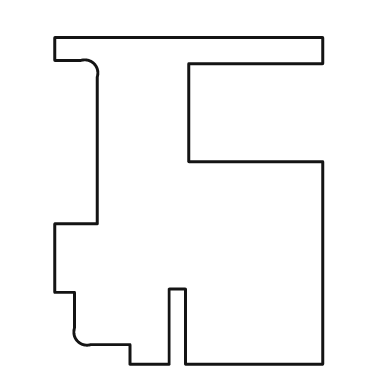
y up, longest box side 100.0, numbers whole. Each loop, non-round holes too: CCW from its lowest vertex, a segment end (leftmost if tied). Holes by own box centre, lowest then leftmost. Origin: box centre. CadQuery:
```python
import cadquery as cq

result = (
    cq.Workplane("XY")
    .moveTo(-18.0, -50.0)
    .lineTo(-6.0, -50.0)
    .lineTo(-6.0, -27.0)
    .lineTo(-1.0, -27.0)
    .lineTo(-1.0, -50.0)
    .lineTo(41.0, -50.0)
    .lineTo(41.0, 12.0)
    .lineTo(0.0, 12.0)
    .lineTo(0.0, 42.0)
    .lineTo(41.0, 42.0)
    .lineTo(41.0, 50.0)
    .lineTo(-41.0, 50.0)
    .lineTo(-41.0, 43.0)
    .lineTo(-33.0, 43.0)
    .threePointArc((-29.0, 42.0), (-28.0, 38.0))
    .lineTo(-28.0, -7.0)
    .lineTo(-41.0, -7.0)
    .lineTo(-41.0, -28.0)
    .lineTo(-35.0, -28.0)
    .lineTo(-35.0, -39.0)
    .threePointArc((-34.0, -43.0), (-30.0, -44.0))
    .lineTo(-18.0, -44.0)
    .close()
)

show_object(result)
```